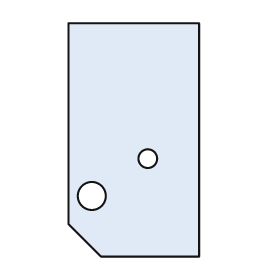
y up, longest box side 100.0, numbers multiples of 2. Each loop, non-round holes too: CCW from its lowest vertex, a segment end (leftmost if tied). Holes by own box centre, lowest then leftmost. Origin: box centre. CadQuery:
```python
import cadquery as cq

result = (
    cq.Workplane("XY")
    .moveTo(-14.0, -50.0)
    .lineTo(28.0, -50.0)
    .lineTo(28.0, 50.0)
    .lineTo(-28.0, 50.0)
    .lineTo(-28.0, -36.0)
    .close()
    .moveTo(-18.0, -24.0)
    .circle(6.0)
    .moveTo(6.0, -8.0)
    .circle(4.0)
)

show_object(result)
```